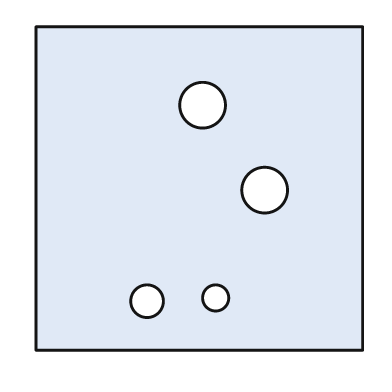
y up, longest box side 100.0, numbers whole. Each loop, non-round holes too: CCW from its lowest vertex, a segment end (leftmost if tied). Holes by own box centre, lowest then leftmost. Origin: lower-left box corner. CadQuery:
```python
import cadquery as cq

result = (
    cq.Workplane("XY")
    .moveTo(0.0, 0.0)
    .lineTo(100.0, 0.0)
    .lineTo(100.0, 99.0)
    .lineTo(0.0, 99.0)
    .close()
    .moveTo(34.0, 15.0)
    .circle(5.0)
    .moveTo(55.0, 16.0)
    .circle(4.0)
    .moveTo(70.0, 49.0)
    .circle(7.0)
    .moveTo(51.0, 75.0)
    .circle(7.0)
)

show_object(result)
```